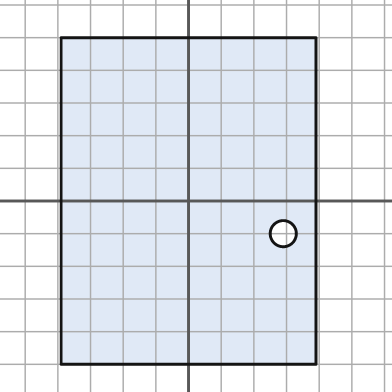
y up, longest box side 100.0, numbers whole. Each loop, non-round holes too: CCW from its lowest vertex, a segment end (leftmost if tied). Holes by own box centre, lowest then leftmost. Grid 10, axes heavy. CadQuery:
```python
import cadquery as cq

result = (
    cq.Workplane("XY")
    .moveTo(-39.0, -50.0)
    .lineTo(39.0, -50.0)
    .lineTo(39.0, 50.0)
    .lineTo(-39.0, 50.0)
    .close()
    .moveTo(29.0, -10.0)
    .circle(4.0)
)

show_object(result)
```